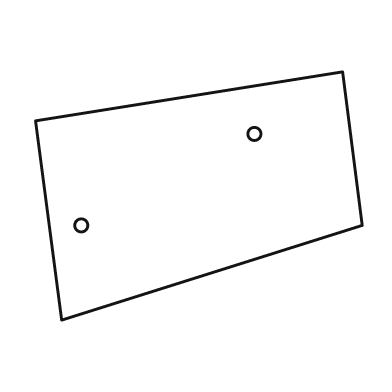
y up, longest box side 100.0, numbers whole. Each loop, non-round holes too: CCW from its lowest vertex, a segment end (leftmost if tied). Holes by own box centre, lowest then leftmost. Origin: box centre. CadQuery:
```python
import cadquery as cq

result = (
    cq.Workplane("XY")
    .moveTo(-42.0, -38.0)
    .lineTo(50.0, -9.0)
    .lineTo(44.0, 38.0)
    .lineTo(-50.0, 23.0)
    .close()
    .moveTo(-36.0, -9.0)
    .circle(2.0)
    .moveTo(17.0, 19.0)
    .circle(2.0)
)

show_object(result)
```